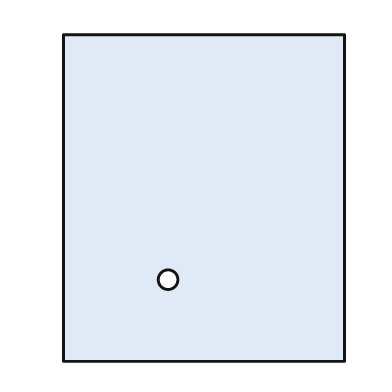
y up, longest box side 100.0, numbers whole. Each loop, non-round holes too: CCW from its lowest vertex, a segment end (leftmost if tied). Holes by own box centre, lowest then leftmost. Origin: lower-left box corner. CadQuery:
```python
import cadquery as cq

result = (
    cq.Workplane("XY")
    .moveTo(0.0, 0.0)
    .lineTo(86.0, 0.0)
    .lineTo(86.0, 100.0)
    .lineTo(0.0, 100.0)
    .close()
    .moveTo(32.0, 25.0)
    .circle(3.0)
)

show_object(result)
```